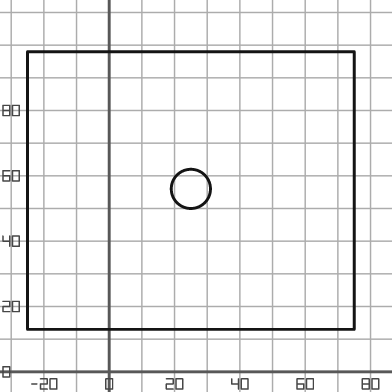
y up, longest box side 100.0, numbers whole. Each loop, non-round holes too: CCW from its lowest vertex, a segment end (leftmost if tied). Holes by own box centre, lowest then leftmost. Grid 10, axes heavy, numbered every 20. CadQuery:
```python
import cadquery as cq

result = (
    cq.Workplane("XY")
    .moveTo(-25.0, 13.0)
    .lineTo(75.0, 13.0)
    .lineTo(75.0, 98.0)
    .lineTo(-25.0, 98.0)
    .close()
    .moveTo(25.0, 56.0)
    .circle(6.0)
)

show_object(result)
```